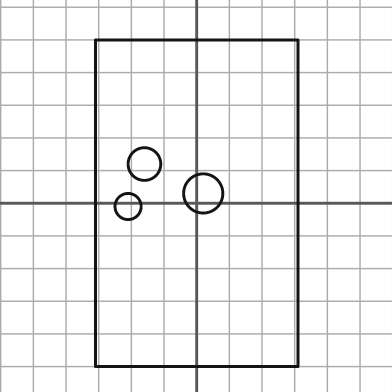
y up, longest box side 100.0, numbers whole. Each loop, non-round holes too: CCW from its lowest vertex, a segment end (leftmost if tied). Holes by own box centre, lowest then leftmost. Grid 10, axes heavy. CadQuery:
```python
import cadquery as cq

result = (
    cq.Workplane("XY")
    .moveTo(-31.0, -50.0)
    .lineTo(31.0, -50.0)
    .lineTo(31.0, 50.0)
    .lineTo(-31.0, 50.0)
    .close()
    .moveTo(-21.0, -1.0)
    .circle(4.0)
    .moveTo(2.0, 3.0)
    .circle(6.0)
    .moveTo(-16.0, 12.0)
    .circle(5.0)
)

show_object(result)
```